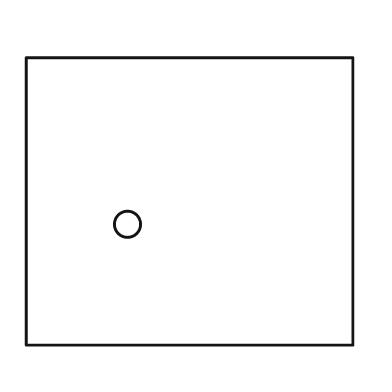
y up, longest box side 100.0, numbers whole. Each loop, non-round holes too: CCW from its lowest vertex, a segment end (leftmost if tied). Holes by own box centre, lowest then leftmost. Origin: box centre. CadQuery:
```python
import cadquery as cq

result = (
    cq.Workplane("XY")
    .moveTo(-50.0, -44.0)
    .lineTo(50.0, -44.0)
    .lineTo(50.0, 44.0)
    .lineTo(-50.0, 44.0)
    .close()
    .moveTo(-19.0, -7.0)
    .circle(4.0)
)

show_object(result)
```